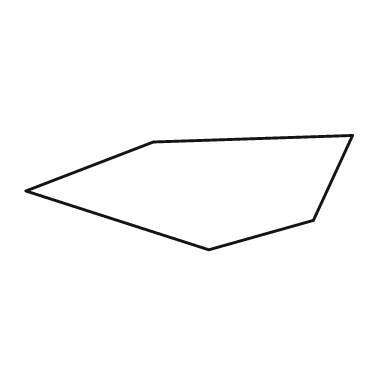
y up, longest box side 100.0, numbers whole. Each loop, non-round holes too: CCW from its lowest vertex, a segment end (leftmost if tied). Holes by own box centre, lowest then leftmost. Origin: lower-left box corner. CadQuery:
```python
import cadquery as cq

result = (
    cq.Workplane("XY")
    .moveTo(56.0, 0.0)
    .lineTo(88.0, 9.0)
    .lineTo(100.0, 35.0)
    .lineTo(39.0, 33.0)
    .lineTo(0.0, 18.0)
    .close()
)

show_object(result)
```